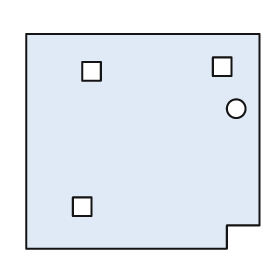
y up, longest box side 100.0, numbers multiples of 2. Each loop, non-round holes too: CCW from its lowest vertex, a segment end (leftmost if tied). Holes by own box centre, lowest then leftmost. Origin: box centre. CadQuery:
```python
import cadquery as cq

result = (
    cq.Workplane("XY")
    .moveTo(-50.0, -46.0)
    .lineTo(36.0, -46.0)
    .lineTo(36.0, -36.0)
    .lineTo(50.0, -36.0)
    .lineTo(50.0, 46.0)
    .lineTo(-50.0, 46.0)
    .close()
    .moveTo(-30.0, -32.0)
    .lineTo(-22.0, -32.0)
    .lineTo(-22.0, -24.0)
    .lineTo(-30.0, -24.0)
    .close()
    .moveTo(40.0, 14.0)
    .circle(4.0)
    .moveTo(-26.0, 26.0)
    .lineTo(-18.0, 26.0)
    .lineTo(-18.0, 34.0)
    .lineTo(-26.0, 34.0)
    .close()
    .moveTo(30.0, 28.0)
    .lineTo(38.0, 28.0)
    .lineTo(38.0, 36.0)
    .lineTo(30.0, 36.0)
    .close()
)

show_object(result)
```